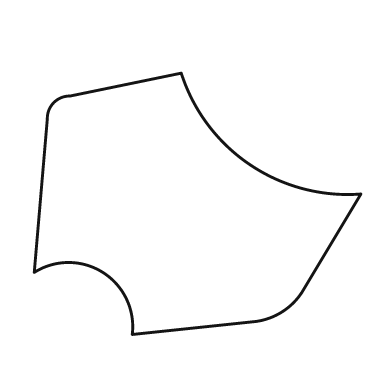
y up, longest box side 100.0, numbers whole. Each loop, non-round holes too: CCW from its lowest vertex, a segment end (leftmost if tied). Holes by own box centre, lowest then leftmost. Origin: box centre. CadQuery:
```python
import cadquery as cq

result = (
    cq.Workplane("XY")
    .moveTo(-20.0, -40.0)
    .lineTo(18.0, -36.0)
    .threePointArc((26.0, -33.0), (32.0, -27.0))
    .lineTo(50.0, 3.0)
    .threePointArc((16.0, 12.0), (-5.0, 40.0))
    .lineTo(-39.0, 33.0)
    .threePointArc((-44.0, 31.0), (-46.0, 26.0))
    .lineTo(-50.0, -21.0)
    .threePointArc((-29.0, -21.0), (-20.0, -40.0))
    .close()
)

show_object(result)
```